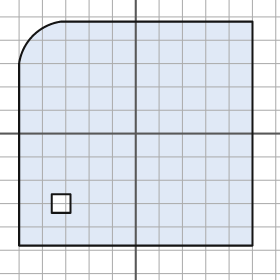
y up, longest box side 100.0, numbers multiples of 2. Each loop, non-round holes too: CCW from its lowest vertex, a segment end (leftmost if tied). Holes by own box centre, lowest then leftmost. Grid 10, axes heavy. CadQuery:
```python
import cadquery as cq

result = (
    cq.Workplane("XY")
    .moveTo(-50.0, -48.0)
    .lineTo(50.0, -48.0)
    .lineTo(50.0, 48.0)
    .lineTo(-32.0, 48.0)
    .threePointArc((-44.0, 42.0), (-50.0, 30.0))
    .close()
    .moveTo(-36.0, -34.0)
    .lineTo(-28.0, -34.0)
    .lineTo(-28.0, -26.0)
    .lineTo(-36.0, -26.0)
    .close()
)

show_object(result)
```